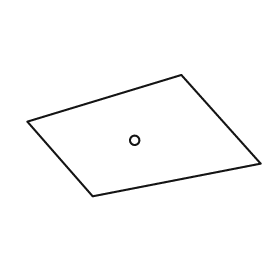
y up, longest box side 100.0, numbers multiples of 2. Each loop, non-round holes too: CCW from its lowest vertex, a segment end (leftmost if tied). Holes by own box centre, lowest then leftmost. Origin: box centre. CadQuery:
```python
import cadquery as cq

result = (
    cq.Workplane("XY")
    .moveTo(-22.0, -26.0)
    .lineTo(50.0, -12.0)
    .lineTo(16.0, 26.0)
    .lineTo(-50.0, 6.0)
    .close()
    .moveTo(-4.0, -2.0)
    .circle(2.0)
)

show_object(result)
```